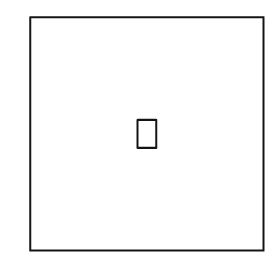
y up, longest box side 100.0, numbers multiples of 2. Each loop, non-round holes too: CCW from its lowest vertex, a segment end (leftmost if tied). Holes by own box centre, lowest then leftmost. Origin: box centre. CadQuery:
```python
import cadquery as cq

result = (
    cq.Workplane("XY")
    .moveTo(-50.0, -50.0)
    .lineTo(50.0, -50.0)
    .lineTo(50.0, 50.0)
    .lineTo(-50.0, 50.0)
    .close()
    .moveTo(-4.0, -6.0)
    .lineTo(4.0, -6.0)
    .lineTo(4.0, 6.0)
    .lineTo(-4.0, 6.0)
    .close()
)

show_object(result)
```